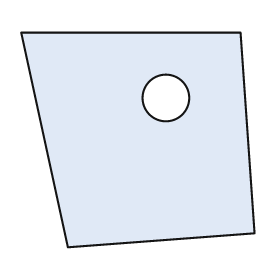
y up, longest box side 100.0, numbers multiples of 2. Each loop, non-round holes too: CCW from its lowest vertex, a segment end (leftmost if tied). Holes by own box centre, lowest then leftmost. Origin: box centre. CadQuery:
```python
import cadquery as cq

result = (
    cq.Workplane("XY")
    .moveTo(-30.0, -46.0)
    .lineTo(50.0, -40.0)
    .lineTo(44.0, 46.0)
    .lineTo(-50.0, 46.0)
    .close()
    .moveTo(12.0, 18.0)
    .circle(10.0)
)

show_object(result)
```